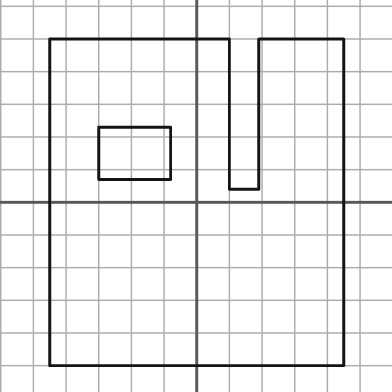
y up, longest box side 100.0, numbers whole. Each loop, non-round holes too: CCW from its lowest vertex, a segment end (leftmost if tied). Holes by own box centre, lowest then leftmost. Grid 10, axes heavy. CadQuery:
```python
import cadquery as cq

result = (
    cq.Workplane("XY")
    .moveTo(-45.0, -50.0)
    .lineTo(45.0, -50.0)
    .lineTo(45.0, 50.0)
    .lineTo(19.0, 50.0)
    .lineTo(19.0, 4.0)
    .lineTo(10.0, 4.0)
    .lineTo(10.0, 50.0)
    .lineTo(-45.0, 50.0)
    .close()
    .moveTo(-30.0, 7.0)
    .lineTo(-8.0, 7.0)
    .lineTo(-8.0, 23.0)
    .lineTo(-30.0, 23.0)
    .close()
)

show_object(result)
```